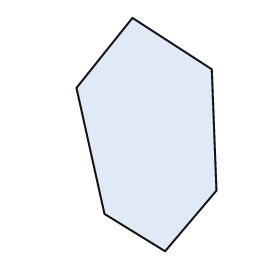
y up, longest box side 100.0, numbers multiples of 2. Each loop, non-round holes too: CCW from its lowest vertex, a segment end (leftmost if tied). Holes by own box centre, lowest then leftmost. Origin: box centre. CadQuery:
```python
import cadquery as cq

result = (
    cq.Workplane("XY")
    .moveTo(8.0, -50.0)
    .lineTo(30.0, -24.0)
    .lineTo(28.0, 28.0)
    .lineTo(-6.0, 50.0)
    .lineTo(-30.0, 20.0)
    .lineTo(-18.0, -34.0)
    .close()
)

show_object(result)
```